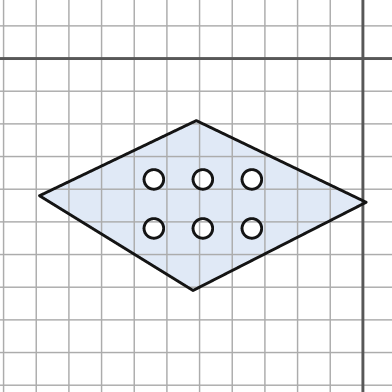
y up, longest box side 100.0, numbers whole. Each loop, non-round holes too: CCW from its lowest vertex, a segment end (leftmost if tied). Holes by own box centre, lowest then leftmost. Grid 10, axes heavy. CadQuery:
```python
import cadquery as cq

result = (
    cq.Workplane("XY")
    .moveTo(-52.0, -71.0)
    .lineTo(1.0, -44.0)
    .lineTo(-51.0, -19.0)
    .lineTo(-99.0, -42.0)
    .close()
    .moveTo(-64.0, -52.0)
    .circle(3.0)
    .moveTo(-49.0, -52.0)
    .circle(3.0)
    .moveTo(-34.0, -52.0)
    .circle(3.0)
    .moveTo(-64.0, -37.0)
    .circle(3.0)
    .moveTo(-49.0, -37.0)
    .circle(3.0)
    .moveTo(-34.0, -37.0)
    .circle(3.0)
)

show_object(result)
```